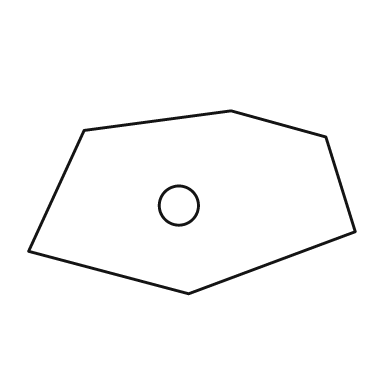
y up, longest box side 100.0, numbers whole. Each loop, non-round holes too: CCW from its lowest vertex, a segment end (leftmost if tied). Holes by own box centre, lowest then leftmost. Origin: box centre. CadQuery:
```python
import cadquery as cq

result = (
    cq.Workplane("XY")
    .moveTo(-1.0, -28.0)
    .lineTo(50.0, -9.0)
    .lineTo(41.0, 20.0)
    .lineTo(12.0, 28.0)
    .lineTo(-33.0, 22.0)
    .lineTo(-50.0, -15.0)
    .close()
    .moveTo(-4.0, -1.0)
    .circle(6.0)
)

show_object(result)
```